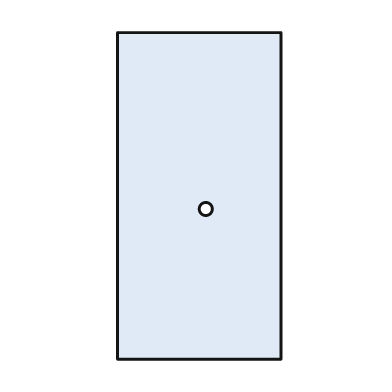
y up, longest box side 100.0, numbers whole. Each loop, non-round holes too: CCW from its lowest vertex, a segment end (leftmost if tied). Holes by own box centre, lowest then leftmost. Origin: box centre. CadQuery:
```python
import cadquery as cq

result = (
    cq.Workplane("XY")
    .moveTo(-25.0, -50.0)
    .lineTo(25.0, -50.0)
    .lineTo(25.0, 50.0)
    .lineTo(-25.0, 50.0)
    .close()
    .moveTo(2.0, -4.0)
    .circle(2.0)
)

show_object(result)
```